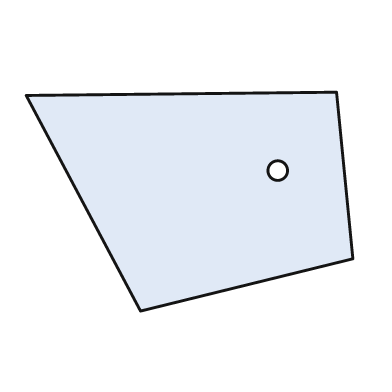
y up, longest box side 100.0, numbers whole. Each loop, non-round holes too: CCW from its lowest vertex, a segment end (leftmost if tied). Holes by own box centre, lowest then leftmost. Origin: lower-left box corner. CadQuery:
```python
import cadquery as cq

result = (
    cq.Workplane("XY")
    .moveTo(35.0, 0.0)
    .lineTo(100.0, 16.0)
    .lineTo(95.0, 67.0)
    .lineTo(0.0, 66.0)
    .close()
    .moveTo(77.0, 43.0)
    .circle(3.0)
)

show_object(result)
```